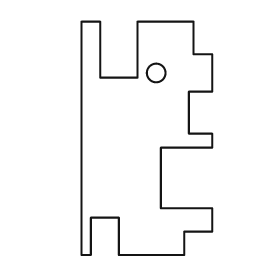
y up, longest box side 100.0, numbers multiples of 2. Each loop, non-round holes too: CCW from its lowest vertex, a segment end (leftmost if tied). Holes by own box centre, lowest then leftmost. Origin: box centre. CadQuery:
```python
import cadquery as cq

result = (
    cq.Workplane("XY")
    .moveTo(-28.0, -50.0)
    .lineTo(-24.0, -50.0)
    .lineTo(-24.0, -34.0)
    .lineTo(-12.0, -34.0)
    .lineTo(-12.0, -50.0)
    .lineTo(16.0, -50.0)
    .lineTo(16.0, -40.0)
    .lineTo(28.0, -40.0)
    .lineTo(28.0, -30.0)
    .lineTo(6.0, -30.0)
    .lineTo(6.0, -4.0)
    .lineTo(28.0, -4.0)
    .lineTo(28.0, 2.0)
    .lineTo(18.0, 2.0)
    .lineTo(18.0, 20.0)
    .lineTo(28.0, 20.0)
    .lineTo(28.0, 36.0)
    .lineTo(20.0, 36.0)
    .lineTo(20.0, 50.0)
    .lineTo(-4.0, 50.0)
    .lineTo(-4.0, 26.0)
    .lineTo(-20.0, 26.0)
    .lineTo(-20.0, 50.0)
    .lineTo(-28.0, 50.0)
    .close()
    .moveTo(4.0, 28.0)
    .circle(4.0)
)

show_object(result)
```